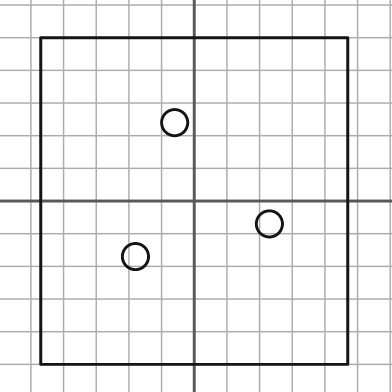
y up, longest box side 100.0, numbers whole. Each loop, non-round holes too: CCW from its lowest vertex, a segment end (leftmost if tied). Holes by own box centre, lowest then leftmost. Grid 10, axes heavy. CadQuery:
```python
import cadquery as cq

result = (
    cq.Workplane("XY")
    .moveTo(-47.0, -50.0)
    .lineTo(47.0, -50.0)
    .lineTo(47.0, 50.0)
    .lineTo(-47.0, 50.0)
    .close()
    .moveTo(-18.0, -17.0)
    .circle(4.0)
    .moveTo(23.0, -7.0)
    .circle(4.0)
    .moveTo(-6.0, 24.0)
    .circle(4.0)
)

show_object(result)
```